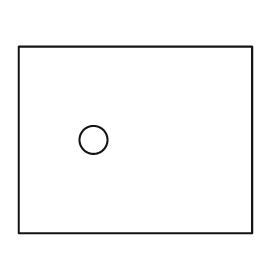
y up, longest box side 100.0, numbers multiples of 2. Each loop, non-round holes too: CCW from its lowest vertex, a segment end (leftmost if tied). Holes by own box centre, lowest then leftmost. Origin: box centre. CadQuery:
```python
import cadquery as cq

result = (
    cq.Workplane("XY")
    .moveTo(-50.0, -40.0)
    .lineTo(50.0, -40.0)
    .lineTo(50.0, 40.0)
    .lineTo(-50.0, 40.0)
    .close()
    .moveTo(-18.0, 0.0)
    .circle(6.0)
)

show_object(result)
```